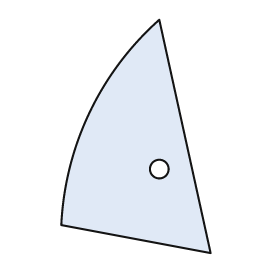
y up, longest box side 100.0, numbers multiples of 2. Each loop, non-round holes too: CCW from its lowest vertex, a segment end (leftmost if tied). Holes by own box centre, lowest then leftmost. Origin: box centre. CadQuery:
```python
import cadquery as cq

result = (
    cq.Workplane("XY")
    .moveTo(32.0, -50.0)
    .lineTo(10.0, 50.0)
    .threePointArc((-20.0, 10.0), (-32.0, -38.0))
    .close()
    .moveTo(10.0, -14.0)
    .circle(4.0)
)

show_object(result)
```